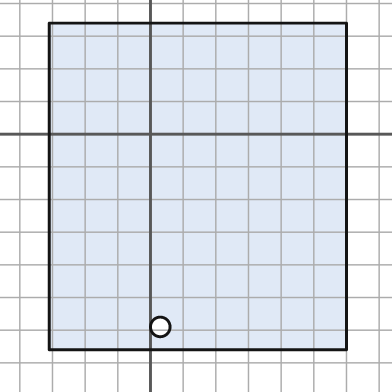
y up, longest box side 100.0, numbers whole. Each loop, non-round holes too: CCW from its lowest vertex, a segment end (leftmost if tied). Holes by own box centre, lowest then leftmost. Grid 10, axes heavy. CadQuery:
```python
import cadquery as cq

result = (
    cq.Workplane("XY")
    .moveTo(-31.0, -66.0)
    .lineTo(60.0, -66.0)
    .lineTo(60.0, 34.0)
    .lineTo(-31.0, 34.0)
    .close()
    .moveTo(3.0, -59.0)
    .circle(3.0)
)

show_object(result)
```